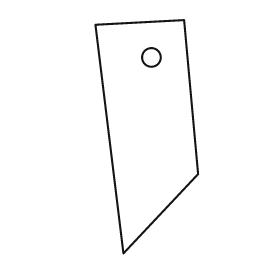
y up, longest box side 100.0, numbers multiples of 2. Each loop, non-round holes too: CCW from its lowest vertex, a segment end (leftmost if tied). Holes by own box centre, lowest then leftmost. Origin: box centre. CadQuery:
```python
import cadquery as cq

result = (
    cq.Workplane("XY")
    .moveTo(-10.0, -50.0)
    .lineTo(22.0, -16.0)
    .lineTo(16.0, 50.0)
    .lineTo(-22.0, 48.0)
    .close()
    .moveTo(2.0, 34.0)
    .circle(4.0)
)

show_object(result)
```